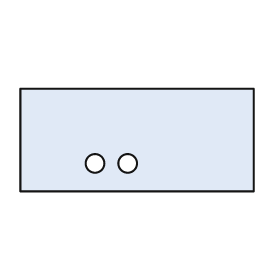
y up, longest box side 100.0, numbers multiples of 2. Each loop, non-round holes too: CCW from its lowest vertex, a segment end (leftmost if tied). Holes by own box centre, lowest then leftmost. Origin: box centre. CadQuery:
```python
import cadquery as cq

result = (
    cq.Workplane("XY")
    .moveTo(-50.0, -22.0)
    .lineTo(50.0, -22.0)
    .lineTo(50.0, 22.0)
    .lineTo(-50.0, 22.0)
    .close()
    .moveTo(-18.0, -10.0)
    .circle(4.0)
    .moveTo(-4.0, -10.0)
    .circle(4.0)
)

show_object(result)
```